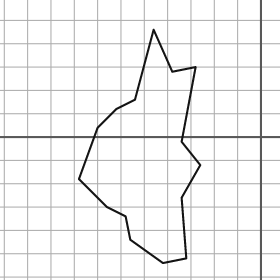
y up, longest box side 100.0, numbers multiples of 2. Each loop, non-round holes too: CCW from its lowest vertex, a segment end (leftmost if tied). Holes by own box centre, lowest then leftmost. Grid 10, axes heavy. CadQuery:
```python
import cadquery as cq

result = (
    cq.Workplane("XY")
    .moveTo(-42.0, -54.0)
    .lineTo(-32.0, -52.0)
    .lineTo(-34.0, -26.0)
    .lineTo(-26.0, -12.0)
    .lineTo(-34.0, -2.0)
    .lineTo(-28.0, 30.0)
    .lineTo(-38.0, 28.0)
    .lineTo(-46.0, 46.0)
    .lineTo(-54.0, 16.0)
    .lineTo(-62.0, 12.0)
    .lineTo(-70.0, 4.0)
    .lineTo(-78.0, -18.0)
    .lineTo(-66.0, -30.0)
    .lineTo(-58.0, -34.0)
    .lineTo(-56.0, -44.0)
    .close()
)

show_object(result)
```